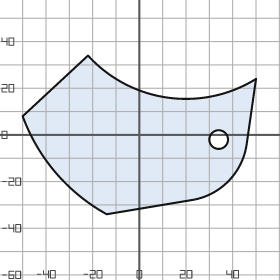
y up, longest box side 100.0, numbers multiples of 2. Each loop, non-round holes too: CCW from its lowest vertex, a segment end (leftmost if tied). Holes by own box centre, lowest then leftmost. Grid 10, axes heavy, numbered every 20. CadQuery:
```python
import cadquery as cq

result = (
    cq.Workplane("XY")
    .moveTo(-14.0, -34.0)
    .lineTo(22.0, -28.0)
    .threePointArc((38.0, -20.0), (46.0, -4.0))
    .lineTo(50.0, 24.0)
    .threePointArc((12.0, 16.0), (-22.0, 34.0))
    .lineTo(-50.0, 8.0)
    .threePointArc((-36.0, -16.0), (-14.0, -34.0))
    .close()
    .moveTo(34.0, -2.0)
    .circle(4.0)
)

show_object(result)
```